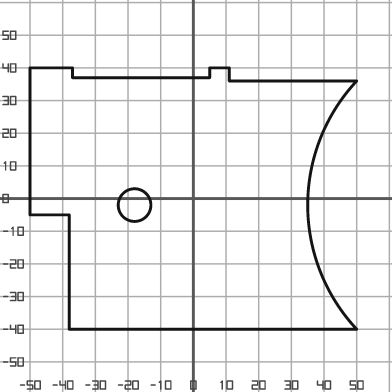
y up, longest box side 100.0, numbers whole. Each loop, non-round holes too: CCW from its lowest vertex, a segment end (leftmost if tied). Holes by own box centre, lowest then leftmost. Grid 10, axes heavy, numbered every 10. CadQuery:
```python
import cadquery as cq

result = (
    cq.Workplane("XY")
    .moveTo(-38.0, -40.0)
    .lineTo(50.0, -40.0)
    .threePointArc((35.0, -2.0), (50.0, 36.0))
    .lineTo(11.0, 36.0)
    .lineTo(11.0, 40.0)
    .lineTo(5.0, 40.0)
    .lineTo(5.0, 37.0)
    .lineTo(-37.0, 37.0)
    .lineTo(-37.0, 40.0)
    .lineTo(-50.0, 40.0)
    .lineTo(-50.0, -5.0)
    .lineTo(-38.0, -5.0)
    .close()
    .moveTo(-18.0, -2.0)
    .circle(5.0)
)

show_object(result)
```